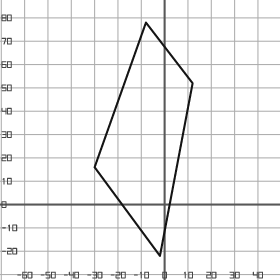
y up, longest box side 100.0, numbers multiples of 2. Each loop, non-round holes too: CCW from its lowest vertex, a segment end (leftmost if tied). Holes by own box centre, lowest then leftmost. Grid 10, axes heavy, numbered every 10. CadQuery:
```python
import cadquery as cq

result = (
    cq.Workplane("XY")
    .moveTo(-2.0, -22.0)
    .lineTo(12.0, 52.0)
    .lineTo(-8.0, 78.0)
    .lineTo(-30.0, 16.0)
    .close()
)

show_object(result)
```